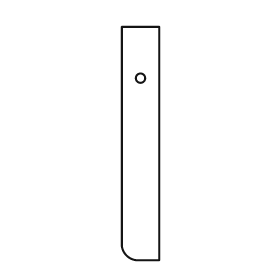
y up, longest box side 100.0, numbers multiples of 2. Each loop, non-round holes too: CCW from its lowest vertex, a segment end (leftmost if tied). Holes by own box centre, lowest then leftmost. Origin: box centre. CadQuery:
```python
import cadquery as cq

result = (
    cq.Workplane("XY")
    .moveTo(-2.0, -50.0)
    .lineTo(8.0, -50.0)
    .lineTo(8.0, 50.0)
    .lineTo(-8.0, 50.0)
    .lineTo(-8.0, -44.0)
    .threePointArc((-6.0, -48.0), (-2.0, -50.0))
    .close()
    .moveTo(0.0, 28.0)
    .circle(2.0)
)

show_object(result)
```